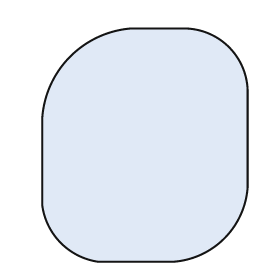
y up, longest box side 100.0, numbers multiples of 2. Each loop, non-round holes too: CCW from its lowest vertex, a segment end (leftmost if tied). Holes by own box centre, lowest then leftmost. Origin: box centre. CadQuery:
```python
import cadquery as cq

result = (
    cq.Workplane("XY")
    .moveTo(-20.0, -50.0)
    .lineTo(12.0, -50.0)
    .threePointArc((34.0, -40.0), (44.0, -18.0))
    .lineTo(44.0, 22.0)
    .threePointArc((36.0, 42.0), (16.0, 50.0))
    .lineTo(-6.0, 50.0)
    .threePointArc((-32.0, 38.0), (-44.0, 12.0))
    .lineTo(-44.0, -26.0)
    .threePointArc((-36.0, -42.0), (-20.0, -50.0))
    .close()
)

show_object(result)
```